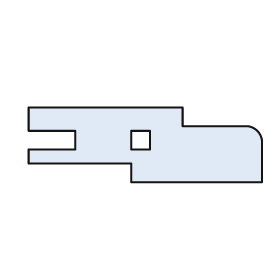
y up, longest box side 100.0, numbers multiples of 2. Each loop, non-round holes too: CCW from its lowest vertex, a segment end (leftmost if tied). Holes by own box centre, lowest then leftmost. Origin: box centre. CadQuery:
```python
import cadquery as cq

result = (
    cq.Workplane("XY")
    .moveTo(-6.0, -16.0)
    .lineTo(50.0, -16.0)
    .lineTo(50.0, 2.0)
    .threePointArc((48.0, 6.0), (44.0, 8.0))
    .lineTo(16.0, 8.0)
    .lineTo(16.0, 16.0)
    .lineTo(-50.0, 16.0)
    .lineTo(-50.0, 6.0)
    .lineTo(-30.0, 6.0)
    .lineTo(-30.0, -2.0)
    .lineTo(-50.0, -2.0)
    .lineTo(-50.0, -8.0)
    .lineTo(-6.0, -8.0)
    .close()
    .moveTo(-6.0, -2.0)
    .lineTo(2.0, -2.0)
    .lineTo(2.0, 6.0)
    .lineTo(-6.0, 6.0)
    .close()
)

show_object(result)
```